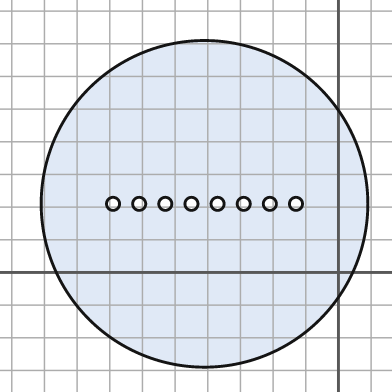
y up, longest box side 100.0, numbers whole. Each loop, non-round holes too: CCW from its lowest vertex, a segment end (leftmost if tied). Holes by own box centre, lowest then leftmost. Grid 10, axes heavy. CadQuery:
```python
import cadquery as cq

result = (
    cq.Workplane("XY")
    .moveTo(-41.0, 21.0)
    .circle(50.0)
    .moveTo(-69.0, 21.0)
    .circle(2.0)
    .moveTo(-61.0, 21.0)
    .circle(2.0)
    .moveTo(-53.0, 21.0)
    .circle(2.0)
    .moveTo(-45.0, 21.0)
    .circle(2.0)
    .moveTo(-37.0, 21.0)
    .circle(2.0)
    .moveTo(-29.0, 21.0)
    .circle(2.0)
    .moveTo(-21.0, 21.0)
    .circle(2.0)
    .moveTo(-13.0, 21.0)
    .circle(2.0)
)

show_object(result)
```